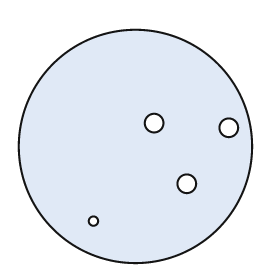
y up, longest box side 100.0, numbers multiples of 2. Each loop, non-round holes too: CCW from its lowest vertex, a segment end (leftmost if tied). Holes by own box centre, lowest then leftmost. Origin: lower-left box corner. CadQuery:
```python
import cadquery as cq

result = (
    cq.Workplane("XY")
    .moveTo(50.0, 50.0)
    .circle(50.0)
    .moveTo(32.0, 18.0)
    .circle(2.0)
    .moveTo(72.0, 34.0)
    .circle(4.0)
    .moveTo(90.0, 58.0)
    .circle(4.0)
    .moveTo(58.0, 60.0)
    .circle(4.0)
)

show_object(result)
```